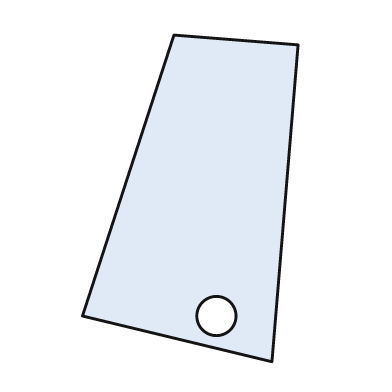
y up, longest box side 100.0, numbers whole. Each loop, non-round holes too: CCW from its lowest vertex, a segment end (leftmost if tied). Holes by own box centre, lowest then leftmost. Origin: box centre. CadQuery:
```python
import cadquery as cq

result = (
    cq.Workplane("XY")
    .moveTo(25.0, -50.0)
    .lineTo(33.0, 47.0)
    .lineTo(-5.0, 50.0)
    .lineTo(-33.0, -36.0)
    .close()
    .moveTo(8.0, -36.0)
    .circle(6.0)
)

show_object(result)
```